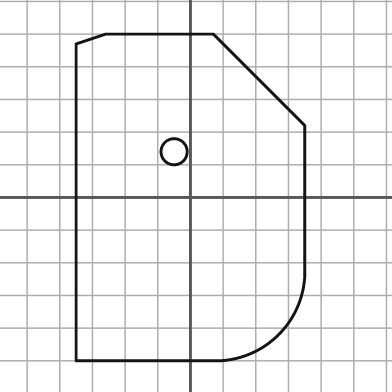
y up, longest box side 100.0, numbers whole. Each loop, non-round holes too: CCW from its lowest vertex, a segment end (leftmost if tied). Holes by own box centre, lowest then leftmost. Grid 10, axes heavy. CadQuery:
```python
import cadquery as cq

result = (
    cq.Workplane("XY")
    .moveTo(-35.0, -50.0)
    .lineTo(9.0, -50.0)
    .threePointArc((27.0, -42.0), (35.0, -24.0))
    .lineTo(35.0, 22.0)
    .lineTo(7.0, 50.0)
    .lineTo(-26.0, 50.0)
    .lineTo(-35.0, 47.0)
    .close()
    .moveTo(-5.0, 14.0)
    .circle(4.0)
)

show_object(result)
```